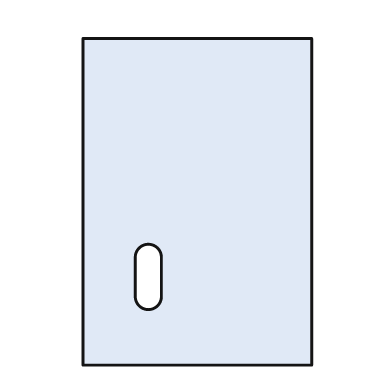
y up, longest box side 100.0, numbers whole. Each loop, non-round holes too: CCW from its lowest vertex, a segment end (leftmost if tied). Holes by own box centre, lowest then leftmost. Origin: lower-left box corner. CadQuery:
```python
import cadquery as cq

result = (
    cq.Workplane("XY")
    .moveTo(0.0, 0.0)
    .lineTo(70.0, 0.0)
    .lineTo(70.0, 100.0)
    .lineTo(0.0, 100.0)
    .close()
    .moveTo(16.0, 21.0)
    .threePointArc((20.0, 17.0), (24.0, 21.0))
    .lineTo(24.0, 33.0)
    .threePointArc((20.0, 37.0), (16.0, 33.0))
    .close()
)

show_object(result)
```